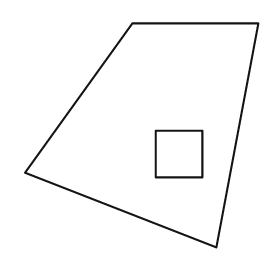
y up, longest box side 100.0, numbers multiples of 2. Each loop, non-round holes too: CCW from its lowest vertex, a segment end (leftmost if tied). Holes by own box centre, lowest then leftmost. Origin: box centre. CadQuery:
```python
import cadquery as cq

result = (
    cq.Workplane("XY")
    .moveTo(32.0, -48.0)
    .lineTo(50.0, 48.0)
    .lineTo(-4.0, 48.0)
    .lineTo(-50.0, -16.0)
    .close()
    .moveTo(6.0, -18.0)
    .lineTo(26.0, -18.0)
    .lineTo(26.0, 2.0)
    .lineTo(6.0, 2.0)
    .close()
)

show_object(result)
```